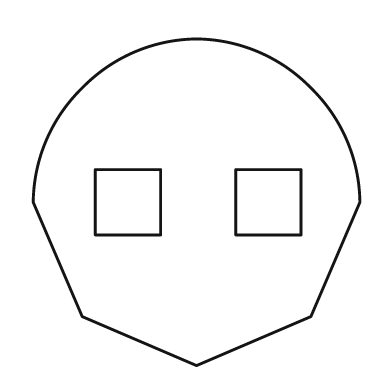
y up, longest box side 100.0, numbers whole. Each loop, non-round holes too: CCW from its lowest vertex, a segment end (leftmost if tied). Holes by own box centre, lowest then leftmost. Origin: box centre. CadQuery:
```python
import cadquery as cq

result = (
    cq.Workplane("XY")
    .moveTo(0.0, -50.0)
    .lineTo(35.0, -35.0)
    .lineTo(50.0, 0.0)
    .threePointArc((46.0, 19.0), (35.0, 35.0))
    .threePointArc((19.0, 46.0), (0.0, 50.0))
    .threePointArc((-19.0, 46.0), (-35.0, 35.0))
    .threePointArc((-46.0, 19.0), (-50.0, 0.0))
    .lineTo(-35.0, -35.0)
    .close()
    .moveTo(-31.0, -10.0)
    .lineTo(-11.0, -10.0)
    .lineTo(-11.0, 10.0)
    .lineTo(-31.0, 10.0)
    .close()
    .moveTo(12.0, -10.0)
    .lineTo(32.0, -10.0)
    .lineTo(32.0, 10.0)
    .lineTo(12.0, 10.0)
    .close()
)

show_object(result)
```